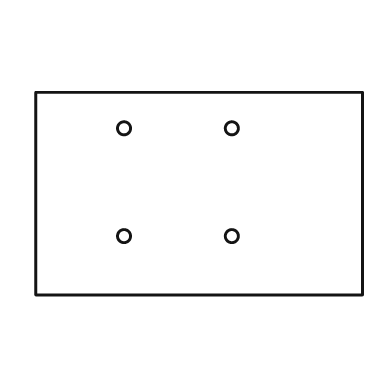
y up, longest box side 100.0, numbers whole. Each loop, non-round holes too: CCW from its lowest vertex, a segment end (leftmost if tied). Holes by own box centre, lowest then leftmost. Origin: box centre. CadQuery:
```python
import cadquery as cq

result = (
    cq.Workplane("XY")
    .moveTo(-50.0, -31.0)
    .lineTo(50.0, -31.0)
    .lineTo(50.0, 31.0)
    .lineTo(-50.0, 31.0)
    .close()
    .moveTo(-23.0, -13.0)
    .circle(2.0)
    .moveTo(10.0, -13.0)
    .circle(2.0)
    .moveTo(-23.0, 20.0)
    .circle(2.0)
    .moveTo(10.0, 20.0)
    .circle(2.0)
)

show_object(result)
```